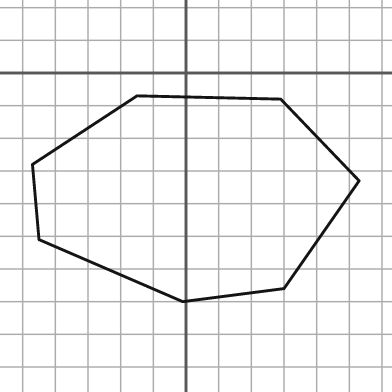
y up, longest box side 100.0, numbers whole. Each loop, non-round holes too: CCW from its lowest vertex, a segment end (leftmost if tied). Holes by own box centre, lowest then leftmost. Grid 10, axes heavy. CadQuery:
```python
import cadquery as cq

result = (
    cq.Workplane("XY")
    .moveTo(-1.0, -70.0)
    .lineTo(30.0, -66.0)
    .lineTo(53.0, -33.0)
    .lineTo(29.0, -8.0)
    .lineTo(-15.0, -7.0)
    .lineTo(-47.0, -28.0)
    .lineTo(-45.0, -51.0)
    .close()
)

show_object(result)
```